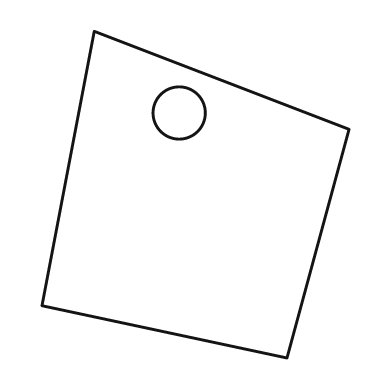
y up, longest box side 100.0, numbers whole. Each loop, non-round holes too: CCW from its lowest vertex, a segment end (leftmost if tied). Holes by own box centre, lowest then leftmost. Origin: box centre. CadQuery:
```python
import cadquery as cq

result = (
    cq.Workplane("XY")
    .moveTo(28.0, -50.0)
    .lineTo(47.0, 20.0)
    .lineTo(-31.0, 50.0)
    .lineTo(-47.0, -34.0)
    .close()
    .moveTo(-5.0, 25.0)
    .circle(8.0)
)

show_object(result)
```